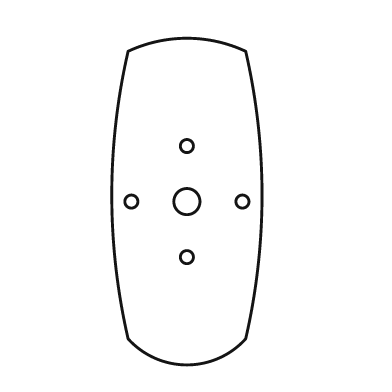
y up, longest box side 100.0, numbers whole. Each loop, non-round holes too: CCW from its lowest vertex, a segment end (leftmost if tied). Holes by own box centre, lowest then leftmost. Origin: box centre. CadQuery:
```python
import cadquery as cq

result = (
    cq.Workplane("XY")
    .moveTo(-18.0, -42.0)
    .threePointArc((0.0, -50.0), (18.0, -42.0))
    .threePointArc((23.0, 2.0), (18.0, 46.0))
    .threePointArc((0.0, 50.0), (-18.0, 46.0))
    .threePointArc((-23.0, 2.0), (-18.0, -42.0))
    .close()
    .moveTo(0.0, -17.0)
    .circle(2.0)
    .moveTo(-17.0, 0.0)
    .circle(2.0)
    .moveTo(0.0, 0.0)
    .circle(4.0)
    .moveTo(17.0, 0.0)
    .circle(2.0)
    .moveTo(0.0, 17.0)
    .circle(2.0)
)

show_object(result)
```